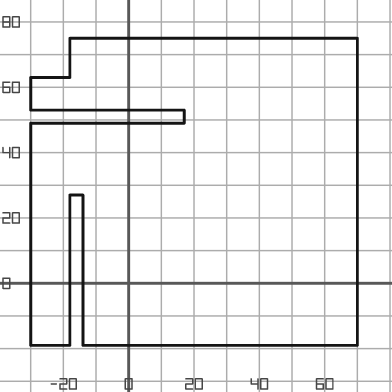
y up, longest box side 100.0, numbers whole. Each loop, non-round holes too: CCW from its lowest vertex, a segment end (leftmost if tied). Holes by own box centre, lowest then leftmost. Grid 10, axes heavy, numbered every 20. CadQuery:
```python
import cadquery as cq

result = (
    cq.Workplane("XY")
    .moveTo(-30.0, -19.0)
    .lineTo(-18.0, -19.0)
    .lineTo(-18.0, 27.0)
    .lineTo(-14.0, 27.0)
    .lineTo(-14.0, -19.0)
    .lineTo(70.0, -19.0)
    .lineTo(70.0, 75.0)
    .lineTo(-18.0, 75.0)
    .lineTo(-18.0, 63.0)
    .lineTo(-30.0, 63.0)
    .lineTo(-30.0, 53.0)
    .lineTo(17.0, 53.0)
    .lineTo(17.0, 49.0)
    .lineTo(-30.0, 49.0)
    .close()
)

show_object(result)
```